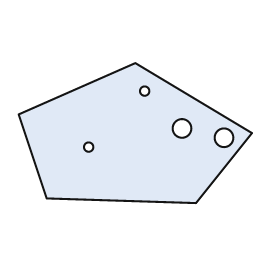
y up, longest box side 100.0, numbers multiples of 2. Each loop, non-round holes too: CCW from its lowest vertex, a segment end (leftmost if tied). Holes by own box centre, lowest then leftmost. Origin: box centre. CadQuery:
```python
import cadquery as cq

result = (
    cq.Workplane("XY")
    .moveTo(26.0, -30.0)
    .lineTo(50.0, 0.0)
    .lineTo(0.0, 30.0)
    .lineTo(-50.0, 8.0)
    .lineTo(-38.0, -28.0)
    .close()
    .moveTo(-20.0, -6.0)
    .circle(2.0)
    .moveTo(38.0, -2.0)
    .circle(4.0)
    .moveTo(20.0, 2.0)
    .circle(4.0)
    .moveTo(4.0, 18.0)
    .circle(2.0)
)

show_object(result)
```